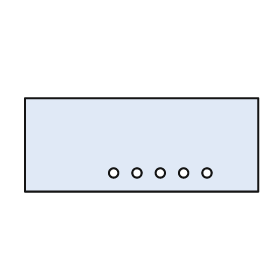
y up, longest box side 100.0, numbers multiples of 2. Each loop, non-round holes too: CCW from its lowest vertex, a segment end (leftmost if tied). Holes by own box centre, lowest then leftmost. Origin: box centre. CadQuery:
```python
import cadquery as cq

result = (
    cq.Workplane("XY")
    .moveTo(-50.0, -20.0)
    .lineTo(50.0, -20.0)
    .lineTo(50.0, 20.0)
    .lineTo(-50.0, 20.0)
    .close()
    .moveTo(-12.0, -12.0)
    .circle(2.0)
    .moveTo(-2.0, -12.0)
    .circle(2.0)
    .moveTo(8.0, -12.0)
    .circle(2.0)
    .moveTo(18.0, -12.0)
    .circle(2.0)
    .moveTo(28.0, -12.0)
    .circle(2.0)
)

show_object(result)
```